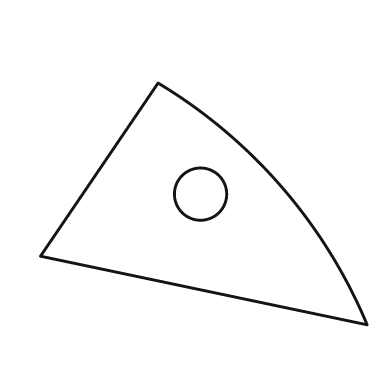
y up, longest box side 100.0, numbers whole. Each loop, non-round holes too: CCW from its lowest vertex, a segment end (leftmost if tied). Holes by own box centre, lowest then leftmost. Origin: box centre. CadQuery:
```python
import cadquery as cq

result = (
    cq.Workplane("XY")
    .moveTo(50.0, -37.0)
    .threePointArc((24.0, 5.0), (-14.0, 37.0))
    .lineTo(-50.0, -16.0)
    .close()
    .moveTo(-1.0, 3.0)
    .circle(8.0)
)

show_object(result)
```